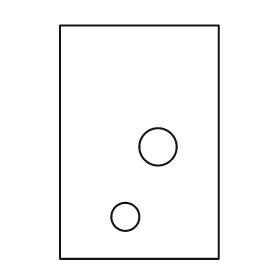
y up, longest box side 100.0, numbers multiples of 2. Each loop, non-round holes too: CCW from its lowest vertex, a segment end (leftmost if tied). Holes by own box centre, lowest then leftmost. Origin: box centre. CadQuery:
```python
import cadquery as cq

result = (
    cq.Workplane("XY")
    .moveTo(-34.0, -50.0)
    .lineTo(34.0, -50.0)
    .lineTo(34.0, 50.0)
    .lineTo(-34.0, 50.0)
    .close()
    .moveTo(-6.0, -32.0)
    .circle(6.0)
    .moveTo(8.0, -2.0)
    .circle(8.0)
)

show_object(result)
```